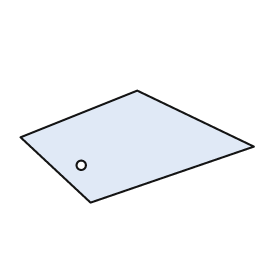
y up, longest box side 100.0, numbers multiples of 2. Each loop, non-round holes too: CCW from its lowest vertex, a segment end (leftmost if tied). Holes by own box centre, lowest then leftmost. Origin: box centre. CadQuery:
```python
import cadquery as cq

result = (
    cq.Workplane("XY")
    .moveTo(-20.0, -24.0)
    .lineTo(50.0, 0.0)
    .lineTo(0.0, 24.0)
    .lineTo(-50.0, 4.0)
    .close()
    .moveTo(-24.0, -8.0)
    .circle(2.0)
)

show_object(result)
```